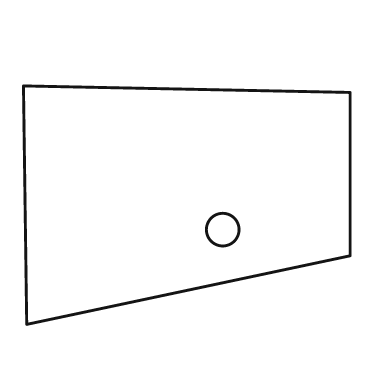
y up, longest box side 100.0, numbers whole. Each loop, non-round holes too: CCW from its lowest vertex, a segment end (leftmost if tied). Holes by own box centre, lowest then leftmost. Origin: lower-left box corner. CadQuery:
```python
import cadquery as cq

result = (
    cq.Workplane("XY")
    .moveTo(1.0, 0.0)
    .lineTo(100.0, 21.0)
    .lineTo(100.0, 71.0)
    .lineTo(0.0, 73.0)
    .close()
    .moveTo(61.0, 29.0)
    .circle(5.0)
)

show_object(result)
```